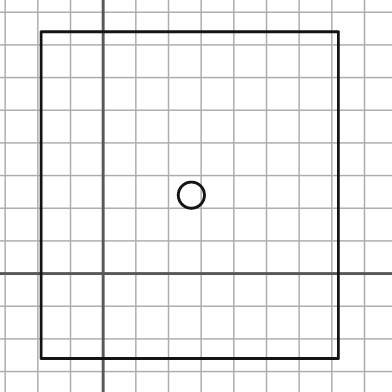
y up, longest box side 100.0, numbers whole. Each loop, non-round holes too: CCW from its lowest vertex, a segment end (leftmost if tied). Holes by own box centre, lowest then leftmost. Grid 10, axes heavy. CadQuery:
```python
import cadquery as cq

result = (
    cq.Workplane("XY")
    .moveTo(-19.0, -26.0)
    .lineTo(72.0, -26.0)
    .lineTo(72.0, 74.0)
    .lineTo(-19.0, 74.0)
    .close()
    .moveTo(27.0, 24.0)
    .circle(4.0)
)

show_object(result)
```